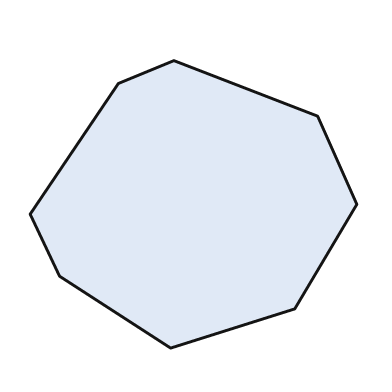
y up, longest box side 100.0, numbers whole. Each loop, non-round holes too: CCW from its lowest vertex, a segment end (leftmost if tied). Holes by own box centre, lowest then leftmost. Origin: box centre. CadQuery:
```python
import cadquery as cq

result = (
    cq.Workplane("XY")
    .moveTo(-7.0, -44.0)
    .lineTo(31.0, -32.0)
    .lineTo(50.0, 0.0)
    .lineTo(38.0, 27.0)
    .lineTo(-6.0, 44.0)
    .lineTo(-23.0, 37.0)
    .lineTo(-50.0, -3.0)
    .lineTo(-41.0, -22.0)
    .close()
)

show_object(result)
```